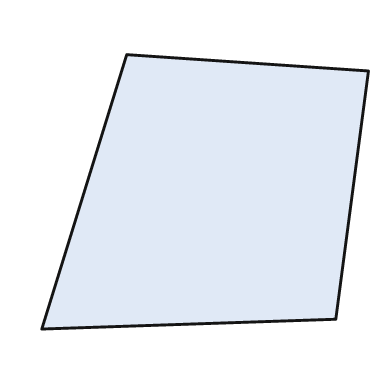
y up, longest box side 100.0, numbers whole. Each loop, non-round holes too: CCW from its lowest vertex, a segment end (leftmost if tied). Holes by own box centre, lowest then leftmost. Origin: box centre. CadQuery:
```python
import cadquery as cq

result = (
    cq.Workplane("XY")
    .moveTo(-50.0, -42.0)
    .lineTo(40.0, -39.0)
    .lineTo(50.0, 37.0)
    .lineTo(-24.0, 42.0)
    .close()
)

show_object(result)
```